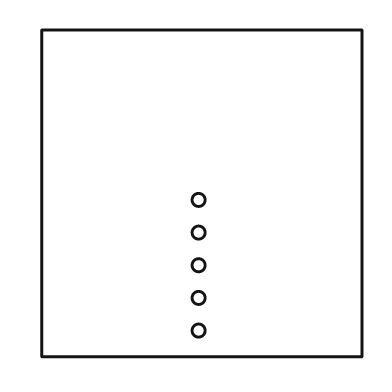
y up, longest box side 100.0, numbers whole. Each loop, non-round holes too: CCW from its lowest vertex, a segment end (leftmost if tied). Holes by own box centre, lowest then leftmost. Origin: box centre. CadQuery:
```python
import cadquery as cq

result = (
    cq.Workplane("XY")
    .moveTo(-49.0, -50.0)
    .lineTo(49.0, -50.0)
    .lineTo(49.0, 50.0)
    .lineTo(-49.0, 50.0)
    .close()
    .moveTo(-1.0, -42.0)
    .circle(2.0)
    .moveTo(-1.0, -32.0)
    .circle(2.0)
    .moveTo(-1.0, -22.0)
    .circle(2.0)
    .moveTo(-1.0, -12.0)
    .circle(2.0)
    .moveTo(-1.0, -2.0)
    .circle(2.0)
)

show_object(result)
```